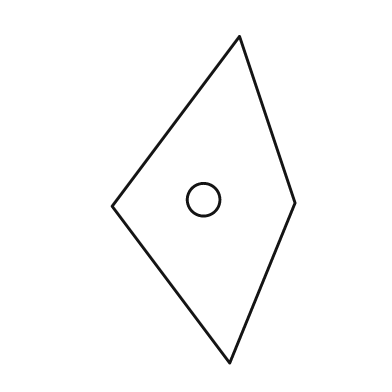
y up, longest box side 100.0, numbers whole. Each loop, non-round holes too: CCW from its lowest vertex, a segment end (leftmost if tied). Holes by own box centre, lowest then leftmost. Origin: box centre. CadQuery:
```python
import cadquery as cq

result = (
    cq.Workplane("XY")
    .moveTo(8.0, -50.0)
    .lineTo(28.0, -1.0)
    .lineTo(11.0, 50.0)
    .lineTo(-28.0, -2.0)
    .close()
    .moveTo(0.0, 0.0)
    .circle(5.0)
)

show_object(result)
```